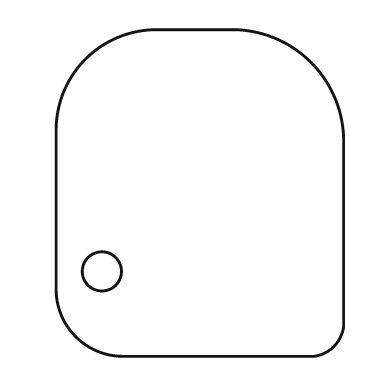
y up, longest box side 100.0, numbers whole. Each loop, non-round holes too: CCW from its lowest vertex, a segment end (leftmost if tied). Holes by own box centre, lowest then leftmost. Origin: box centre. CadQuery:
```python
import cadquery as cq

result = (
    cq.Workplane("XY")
    .moveTo(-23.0, -50.0)
    .lineTo(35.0, -50.0)
    .threePointArc((41.0, -47.0), (44.0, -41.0))
    .lineTo(44.0, 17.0)
    .threePointArc((34.0, 40.0), (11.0, 50.0))
    .lineTo(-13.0, 50.0)
    .threePointArc((-35.0, 41.0), (-44.0, 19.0))
    .lineTo(-44.0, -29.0)
    .threePointArc((-38.0, -44.0), (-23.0, -50.0))
    .close()
    .moveTo(-30.0, -24.0)
    .circle(6.0)
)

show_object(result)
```